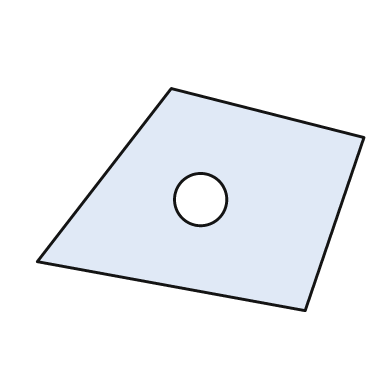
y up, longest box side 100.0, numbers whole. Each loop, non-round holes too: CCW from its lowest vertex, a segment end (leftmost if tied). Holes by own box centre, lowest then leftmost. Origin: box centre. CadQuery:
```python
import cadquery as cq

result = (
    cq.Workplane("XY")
    .moveTo(32.0, -34.0)
    .lineTo(50.0, 19.0)
    .lineTo(-9.0, 34.0)
    .lineTo(-50.0, -19.0)
    .close()
    .moveTo(0.0, 0.0)
    .circle(8.0)
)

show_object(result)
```